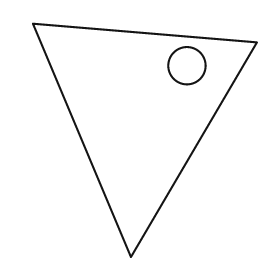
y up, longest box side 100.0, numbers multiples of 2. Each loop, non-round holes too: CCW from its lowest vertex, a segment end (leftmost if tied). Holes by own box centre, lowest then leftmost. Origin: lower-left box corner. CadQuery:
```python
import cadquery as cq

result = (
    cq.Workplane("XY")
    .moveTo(42.0, 0.0)
    .lineTo(96.0, 92.0)
    .lineTo(0.0, 100.0)
    .close()
    .moveTo(66.0, 82.0)
    .circle(8.0)
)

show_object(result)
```